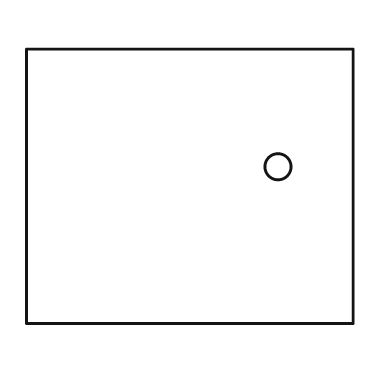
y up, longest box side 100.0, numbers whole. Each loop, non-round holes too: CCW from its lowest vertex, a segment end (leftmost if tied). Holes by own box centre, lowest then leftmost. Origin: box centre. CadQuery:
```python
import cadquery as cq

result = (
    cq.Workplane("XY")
    .moveTo(-50.0, -42.0)
    .lineTo(50.0, -42.0)
    .lineTo(50.0, 42.0)
    .lineTo(-50.0, 42.0)
    .close()
    .moveTo(27.0, 6.0)
    .circle(4.0)
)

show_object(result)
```